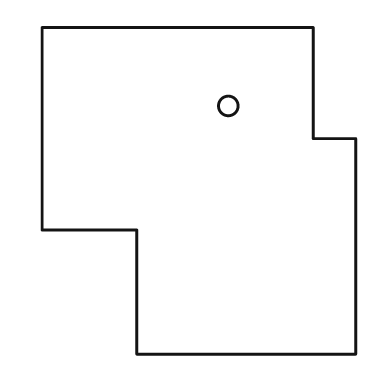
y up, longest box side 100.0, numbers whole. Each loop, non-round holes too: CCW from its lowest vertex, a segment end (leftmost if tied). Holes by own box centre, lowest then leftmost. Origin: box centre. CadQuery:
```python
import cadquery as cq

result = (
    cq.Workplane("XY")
    .moveTo(-19.0, -50.0)
    .lineTo(48.0, -50.0)
    .lineTo(48.0, 16.0)
    .lineTo(35.0, 16.0)
    .lineTo(35.0, 50.0)
    .lineTo(-48.0, 50.0)
    .lineTo(-48.0, -12.0)
    .lineTo(-19.0, -12.0)
    .close()
    .moveTo(9.0, 26.0)
    .circle(3.0)
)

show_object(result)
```